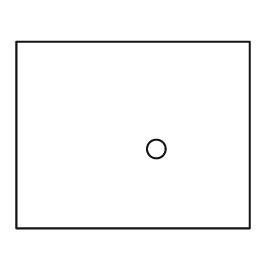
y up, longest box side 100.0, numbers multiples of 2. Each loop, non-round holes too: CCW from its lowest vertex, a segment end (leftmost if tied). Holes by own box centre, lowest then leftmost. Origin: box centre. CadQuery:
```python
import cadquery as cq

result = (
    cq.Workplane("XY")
    .moveTo(-50.0, -40.0)
    .lineTo(50.0, -40.0)
    .lineTo(50.0, 40.0)
    .lineTo(-50.0, 40.0)
    .close()
    .moveTo(10.0, -6.0)
    .circle(4.0)
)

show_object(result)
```